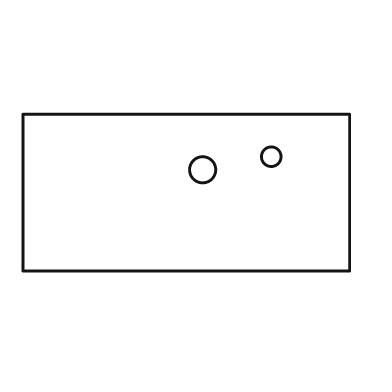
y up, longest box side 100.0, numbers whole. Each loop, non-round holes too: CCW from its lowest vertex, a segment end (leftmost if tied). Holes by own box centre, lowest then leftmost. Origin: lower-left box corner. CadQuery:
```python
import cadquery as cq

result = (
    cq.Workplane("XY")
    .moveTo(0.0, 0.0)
    .lineTo(100.0, 0.0)
    .lineTo(100.0, 48.0)
    .lineTo(0.0, 48.0)
    .close()
    .moveTo(55.0, 31.0)
    .circle(4.0)
    .moveTo(76.0, 35.0)
    .circle(3.0)
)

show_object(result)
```